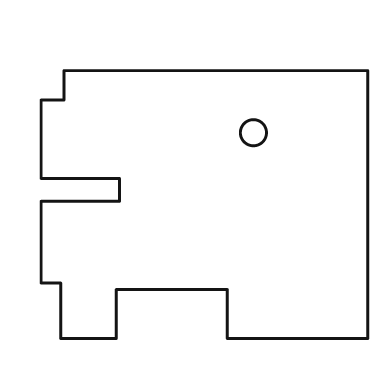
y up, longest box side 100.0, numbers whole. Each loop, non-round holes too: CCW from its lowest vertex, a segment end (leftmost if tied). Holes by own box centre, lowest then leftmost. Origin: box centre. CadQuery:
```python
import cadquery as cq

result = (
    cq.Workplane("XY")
    .moveTo(-44.0, -41.0)
    .lineTo(-27.0, -41.0)
    .lineTo(-27.0, -26.0)
    .lineTo(7.0, -26.0)
    .lineTo(7.0, -41.0)
    .lineTo(50.0, -41.0)
    .lineTo(50.0, 41.0)
    .lineTo(-43.0, 41.0)
    .lineTo(-43.0, 32.0)
    .lineTo(-50.0, 32.0)
    .lineTo(-50.0, 8.0)
    .lineTo(-26.0, 8.0)
    .lineTo(-26.0, 1.0)
    .lineTo(-50.0, 1.0)
    .lineTo(-50.0, -24.0)
    .lineTo(-44.0, -24.0)
    .close()
    .moveTo(15.0, 22.0)
    .circle(4.0)
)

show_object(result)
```